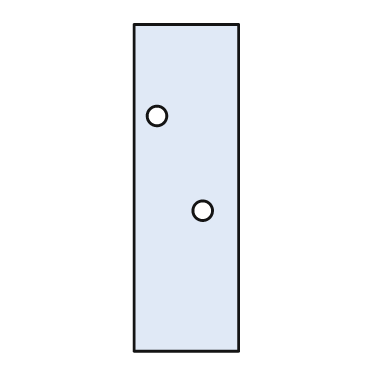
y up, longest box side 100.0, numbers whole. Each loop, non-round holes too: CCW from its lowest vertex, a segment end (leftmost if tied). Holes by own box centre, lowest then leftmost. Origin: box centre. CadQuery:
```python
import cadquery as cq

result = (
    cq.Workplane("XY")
    .moveTo(-16.0, -50.0)
    .lineTo(16.0, -50.0)
    .lineTo(16.0, 50.0)
    .lineTo(-16.0, 50.0)
    .close()
    .moveTo(5.0, -7.0)
    .circle(3.0)
    .moveTo(-9.0, 22.0)
    .circle(3.0)
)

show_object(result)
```